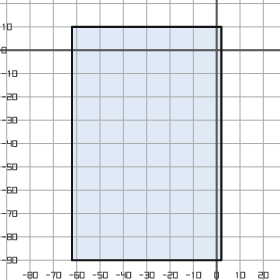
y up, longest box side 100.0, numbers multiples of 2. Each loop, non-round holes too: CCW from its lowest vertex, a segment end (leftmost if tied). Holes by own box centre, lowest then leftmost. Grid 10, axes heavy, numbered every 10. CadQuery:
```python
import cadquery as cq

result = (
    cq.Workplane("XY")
    .moveTo(-62.0, -90.0)
    .lineTo(2.0, -90.0)
    .lineTo(2.0, 10.0)
    .lineTo(-62.0, 10.0)
    .close()
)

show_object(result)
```